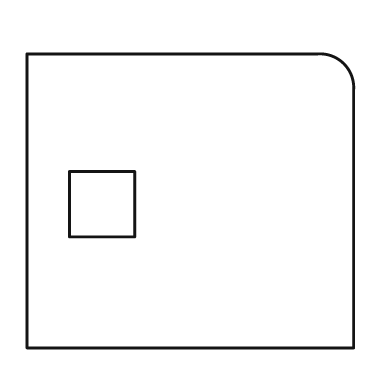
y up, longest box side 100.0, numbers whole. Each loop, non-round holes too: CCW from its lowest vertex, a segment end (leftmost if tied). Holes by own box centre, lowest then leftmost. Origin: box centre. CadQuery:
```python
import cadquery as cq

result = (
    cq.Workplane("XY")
    .moveTo(-50.0, -45.0)
    .lineTo(50.0, -45.0)
    .lineTo(50.0, 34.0)
    .threePointArc((47.0, 42.0), (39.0, 45.0))
    .lineTo(-50.0, 45.0)
    .close()
    .moveTo(-37.0, -11.0)
    .lineTo(-17.0, -11.0)
    .lineTo(-17.0, 9.0)
    .lineTo(-37.0, 9.0)
    .close()
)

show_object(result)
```